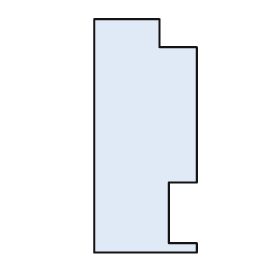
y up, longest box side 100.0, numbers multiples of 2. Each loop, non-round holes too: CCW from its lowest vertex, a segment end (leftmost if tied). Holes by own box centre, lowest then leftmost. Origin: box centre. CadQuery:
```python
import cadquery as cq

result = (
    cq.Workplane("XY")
    .moveTo(-22.0, -50.0)
    .lineTo(22.0, -50.0)
    .lineTo(22.0, -46.0)
    .lineTo(10.0, -46.0)
    .lineTo(10.0, -20.0)
    .lineTo(22.0, -20.0)
    .lineTo(22.0, 38.0)
    .lineTo(6.0, 38.0)
    .lineTo(6.0, 50.0)
    .lineTo(-22.0, 50.0)
    .close()
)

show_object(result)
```